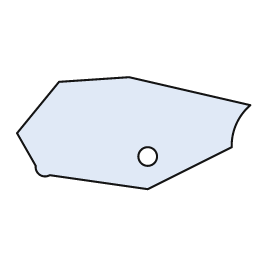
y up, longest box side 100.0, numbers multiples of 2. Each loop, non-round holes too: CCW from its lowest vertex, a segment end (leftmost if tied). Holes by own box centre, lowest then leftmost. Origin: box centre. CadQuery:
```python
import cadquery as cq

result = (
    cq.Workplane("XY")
    .moveTo(6.0, -24.0)
    .lineTo(42.0, -6.0)
    .threePointArc((44.0, 4.0), (50.0, 12.0))
    .lineTo(-2.0, 24.0)
    .lineTo(-32.0, 22.0)
    .lineTo(-50.0, 0.0)
    .lineTo(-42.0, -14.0)
    .threePointArc((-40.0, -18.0), (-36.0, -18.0))
    .close()
    .moveTo(6.0, -10.0)
    .circle(4.0)
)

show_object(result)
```